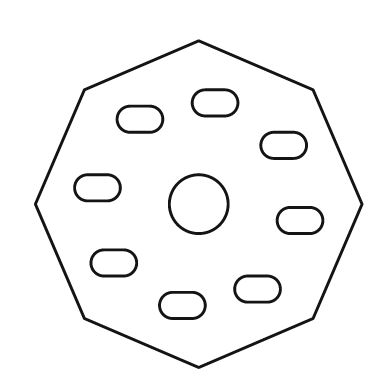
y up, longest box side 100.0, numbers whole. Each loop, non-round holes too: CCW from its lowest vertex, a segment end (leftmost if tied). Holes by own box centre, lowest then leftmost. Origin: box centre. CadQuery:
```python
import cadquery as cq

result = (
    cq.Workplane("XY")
    .moveTo(0.0, -50.0)
    .lineTo(35.0, -35.0)
    .lineTo(50.0, 0.0)
    .lineTo(35.0, 35.0)
    .lineTo(0.0, 50.0)
    .lineTo(-35.0, 35.0)
    .lineTo(-50.0, 0.0)
    .lineTo(-35.0, -35.0)
    .close()
    .moveTo(-8.0, -35.0)
    .lineTo(-2.0, -35.0)
    .threePointArc((2.0, -31.0), (-2.0, -27.0))
    .lineTo(-8.0, -27.0)
    .threePointArc((-12.0, -31.0), (-8.0, -35.0))
    .close()
    .moveTo(15.0, -30.0)
    .lineTo(21.0, -30.0)
    .threePointArc((25.0, -26.0), (21.0, -22.0))
    .lineTo(15.0, -22.0)
    .threePointArc((11.0, -26.0), (15.0, -30.0))
    .close()
    .moveTo(-29.0, -22.0)
    .lineTo(-23.0, -22.0)
    .threePointArc((-19.0, -18.0), (-23.0, -14.0))
    .lineTo(-29.0, -14.0)
    .threePointArc((-33.0, -18.0), (-29.0, -22.0))
    .close()
    .moveTo(28.0, -9.0)
    .lineTo(34.0, -9.0)
    .threePointArc((38.0, -5.0), (34.0, -1.0))
    .lineTo(28.0, -1.0)
    .threePointArc((24.0, -5.0), (28.0, -9.0))
    .close()
    .moveTo(0.0, 0.0)
    .circle(9.0)
    .moveTo(-34.0, 1.0)
    .lineTo(-28.0, 1.0)
    .threePointArc((-24.0, 5.0), (-28.0, 9.0))
    .lineTo(-34.0, 9.0)
    .threePointArc((-38.0, 5.0), (-34.0, 1.0))
    .close()
    .moveTo(23.0, 14.0)
    .lineTo(29.0, 14.0)
    .threePointArc((33.0, 18.0), (29.0, 22.0))
    .lineTo(23.0, 22.0)
    .threePointArc((19.0, 18.0), (23.0, 14.0))
    .close()
    .moveTo(-21.0, 22.0)
    .lineTo(-15.0, 22.0)
    .threePointArc((-11.0, 26.0), (-15.0, 30.0))
    .lineTo(-21.0, 30.0)
    .threePointArc((-25.0, 26.0), (-21.0, 22.0))
    .close()
    .moveTo(2.0, 27.0)
    .lineTo(8.0, 27.0)
    .threePointArc((12.0, 31.0), (8.0, 35.0))
    .lineTo(2.0, 35.0)
    .threePointArc((-2.0, 31.0), (2.0, 27.0))
    .close()
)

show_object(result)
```